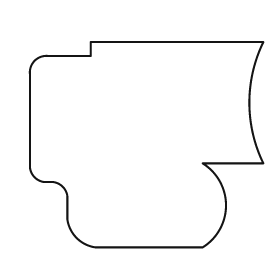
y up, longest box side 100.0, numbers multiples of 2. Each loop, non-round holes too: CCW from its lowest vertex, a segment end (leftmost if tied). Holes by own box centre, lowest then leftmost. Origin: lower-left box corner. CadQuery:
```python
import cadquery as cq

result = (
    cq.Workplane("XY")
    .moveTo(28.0, 0.0)
    .lineTo(74.0, 0.0)
    .threePointArc((84.0, 18.0), (74.0, 36.0))
    .lineTo(100.0, 36.0)
    .threePointArc((94.0, 62.0), (100.0, 88.0))
    .lineTo(26.0, 88.0)
    .lineTo(26.0, 82.0)
    .lineTo(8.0, 82.0)
    .threePointArc((2.0, 80.0), (0.0, 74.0))
    .lineTo(0.0, 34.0)
    .threePointArc((2.0, 30.0), (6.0, 28.0))
    .lineTo(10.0, 28.0)
    .threePointArc((14.0, 26.0), (16.0, 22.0))
    .lineTo(16.0, 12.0)
    .threePointArc((20.0, 4.0), (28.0, 0.0))
    .close()
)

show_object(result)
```